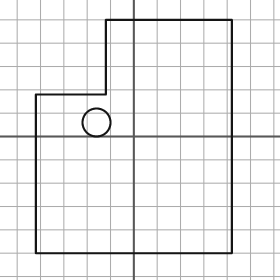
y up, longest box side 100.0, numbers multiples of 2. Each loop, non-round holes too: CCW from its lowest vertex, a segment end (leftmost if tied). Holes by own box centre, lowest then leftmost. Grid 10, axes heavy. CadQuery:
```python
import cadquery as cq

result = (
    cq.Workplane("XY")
    .moveTo(-42.0, -50.0)
    .lineTo(42.0, -50.0)
    .lineTo(42.0, 50.0)
    .lineTo(-12.0, 50.0)
    .lineTo(-12.0, 18.0)
    .lineTo(-42.0, 18.0)
    .close()
    .moveTo(-16.0, 6.0)
    .circle(6.0)
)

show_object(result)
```